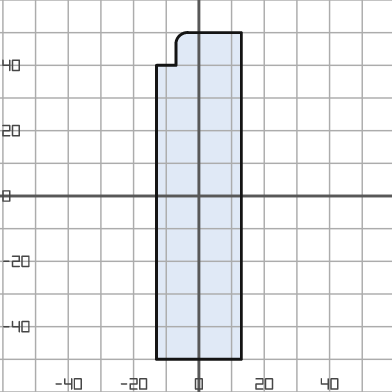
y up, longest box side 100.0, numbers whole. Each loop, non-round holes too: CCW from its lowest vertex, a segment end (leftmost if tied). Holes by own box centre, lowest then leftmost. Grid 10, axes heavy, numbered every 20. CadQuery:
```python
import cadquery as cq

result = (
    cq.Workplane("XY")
    .moveTo(-13.0, -50.0)
    .lineTo(13.0, -50.0)
    .lineTo(13.0, 50.0)
    .lineTo(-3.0, 50.0)
    .threePointArc((-6.0, 49.0), (-7.0, 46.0))
    .lineTo(-7.0, 40.0)
    .lineTo(-13.0, 40.0)
    .close()
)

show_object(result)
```